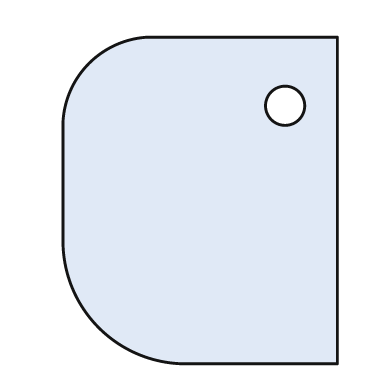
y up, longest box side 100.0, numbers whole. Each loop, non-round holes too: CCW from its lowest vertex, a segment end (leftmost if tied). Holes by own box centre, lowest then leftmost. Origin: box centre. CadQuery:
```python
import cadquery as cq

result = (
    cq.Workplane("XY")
    .moveTo(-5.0, -50.0)
    .lineTo(42.0, -50.0)
    .lineTo(42.0, 50.0)
    .lineTo(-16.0, 50.0)
    .threePointArc((-34.0, 42.0), (-42.0, 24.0))
    .lineTo(-42.0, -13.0)
    .threePointArc((-31.0, -39.0), (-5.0, -50.0))
    .close()
    .moveTo(26.0, 29.0)
    .circle(6.0)
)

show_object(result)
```